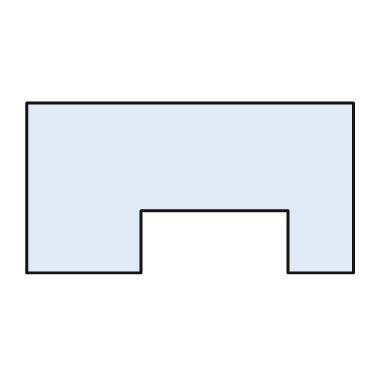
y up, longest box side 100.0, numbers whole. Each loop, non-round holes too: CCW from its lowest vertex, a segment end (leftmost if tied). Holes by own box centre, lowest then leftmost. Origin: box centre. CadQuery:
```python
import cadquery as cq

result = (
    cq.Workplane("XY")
    .moveTo(-50.0, -26.0)
    .lineTo(-15.0, -26.0)
    .lineTo(-15.0, -7.0)
    .lineTo(30.0, -7.0)
    .lineTo(30.0, -26.0)
    .lineTo(50.0, -26.0)
    .lineTo(50.0, 26.0)
    .lineTo(-50.0, 26.0)
    .close()
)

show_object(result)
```